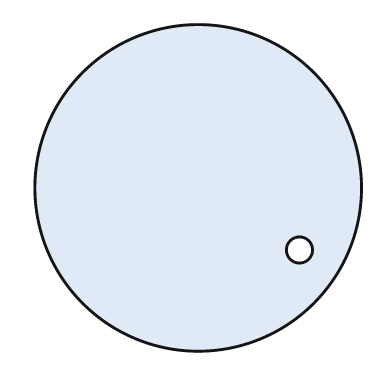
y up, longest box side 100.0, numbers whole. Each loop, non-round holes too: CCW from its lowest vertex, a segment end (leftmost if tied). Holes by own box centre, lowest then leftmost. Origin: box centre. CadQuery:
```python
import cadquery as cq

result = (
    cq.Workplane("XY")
    .moveTo(0.0, 0.0)
    .circle(50.0)
    .moveTo(31.0, -19.0)
    .circle(4.0)
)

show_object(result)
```